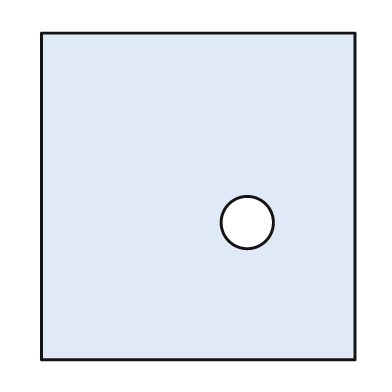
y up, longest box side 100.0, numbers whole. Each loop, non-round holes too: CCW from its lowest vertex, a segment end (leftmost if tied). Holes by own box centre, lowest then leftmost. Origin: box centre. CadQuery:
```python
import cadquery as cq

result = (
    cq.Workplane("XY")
    .moveTo(-48.0, -50.0)
    .lineTo(48.0, -50.0)
    .lineTo(48.0, 50.0)
    .lineTo(-48.0, 50.0)
    .close()
    .moveTo(15.0, -8.0)
    .circle(8.0)
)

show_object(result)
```